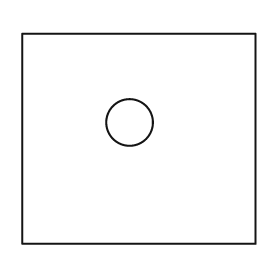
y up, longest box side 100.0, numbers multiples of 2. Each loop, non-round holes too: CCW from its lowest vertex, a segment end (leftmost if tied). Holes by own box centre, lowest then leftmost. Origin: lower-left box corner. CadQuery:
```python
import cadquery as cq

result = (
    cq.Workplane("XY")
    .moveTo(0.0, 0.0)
    .lineTo(100.0, 0.0)
    .lineTo(100.0, 90.0)
    .lineTo(0.0, 90.0)
    .close()
    .moveTo(46.0, 52.0)
    .circle(10.0)
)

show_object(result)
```